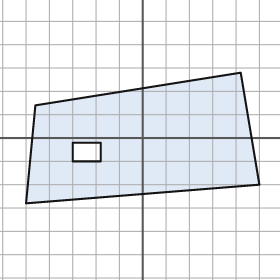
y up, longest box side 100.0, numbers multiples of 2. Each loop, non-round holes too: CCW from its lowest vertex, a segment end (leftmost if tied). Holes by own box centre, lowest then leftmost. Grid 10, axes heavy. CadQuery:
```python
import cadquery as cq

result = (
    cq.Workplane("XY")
    .moveTo(-50.0, -28.0)
    .lineTo(50.0, -20.0)
    .lineTo(42.0, 28.0)
    .lineTo(-46.0, 14.0)
    .close()
    .moveTo(-30.0, -10.0)
    .lineTo(-18.0, -10.0)
    .lineTo(-18.0, -2.0)
    .lineTo(-30.0, -2.0)
    .close()
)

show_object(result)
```